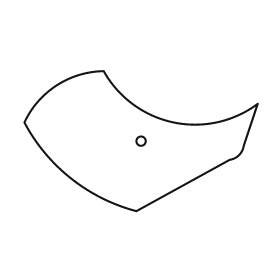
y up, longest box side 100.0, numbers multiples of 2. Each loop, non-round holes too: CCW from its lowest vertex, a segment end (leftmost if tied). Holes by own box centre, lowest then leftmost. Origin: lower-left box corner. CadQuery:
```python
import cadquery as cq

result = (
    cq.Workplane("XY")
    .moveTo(48.0, 0.0)
    .lineTo(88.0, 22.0)
    .threePointArc((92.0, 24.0), (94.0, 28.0))
    .lineTo(100.0, 46.0)
    .threePointArc((64.0, 38.0), (34.0, 60.0))
    .threePointArc((14.0, 54.0), (0.0, 38.0))
    .threePointArc((20.0, 14.0), (48.0, 0.0))
    .close()
    .moveTo(50.0, 30.0)
    .circle(2.0)
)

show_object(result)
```